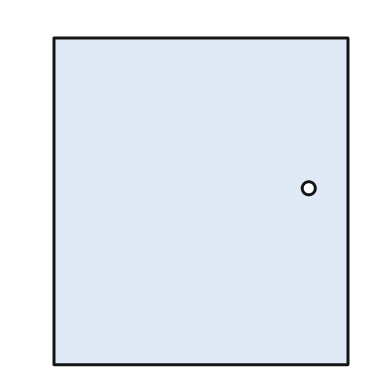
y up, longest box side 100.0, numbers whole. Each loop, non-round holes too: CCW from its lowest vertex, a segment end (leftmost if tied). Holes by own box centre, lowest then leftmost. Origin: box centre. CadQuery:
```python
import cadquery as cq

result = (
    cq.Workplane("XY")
    .moveTo(-45.0, -50.0)
    .lineTo(45.0, -50.0)
    .lineTo(45.0, 50.0)
    .lineTo(-45.0, 50.0)
    .close()
    .moveTo(33.0, 4.0)
    .circle(2.0)
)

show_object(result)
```